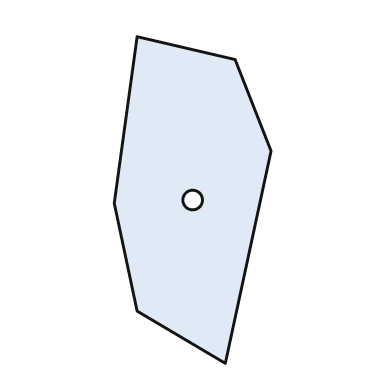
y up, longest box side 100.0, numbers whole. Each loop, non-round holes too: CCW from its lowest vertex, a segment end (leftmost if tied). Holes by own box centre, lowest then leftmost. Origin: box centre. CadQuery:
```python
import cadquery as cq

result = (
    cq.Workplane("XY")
    .moveTo(10.0, -50.0)
    .lineTo(24.0, 15.0)
    .lineTo(13.0, 43.0)
    .lineTo(-17.0, 50.0)
    .lineTo(-24.0, -1.0)
    .lineTo(-17.0, -34.0)
    .close()
    .moveTo(0.0, 0.0)
    .circle(3.0)
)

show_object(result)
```